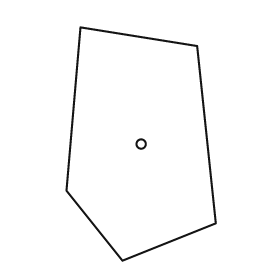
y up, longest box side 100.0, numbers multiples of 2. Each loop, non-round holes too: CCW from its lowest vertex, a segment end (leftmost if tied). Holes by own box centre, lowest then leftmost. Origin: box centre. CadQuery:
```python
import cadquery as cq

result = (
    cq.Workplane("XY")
    .moveTo(-8.0, -50.0)
    .lineTo(32.0, -34.0)
    .lineTo(24.0, 42.0)
    .lineTo(-26.0, 50.0)
    .lineTo(-32.0, -20.0)
    .close()
    .moveTo(0.0, 0.0)
    .circle(2.0)
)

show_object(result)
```